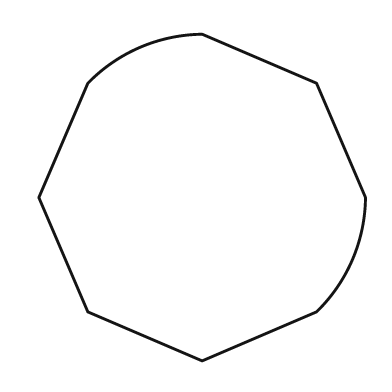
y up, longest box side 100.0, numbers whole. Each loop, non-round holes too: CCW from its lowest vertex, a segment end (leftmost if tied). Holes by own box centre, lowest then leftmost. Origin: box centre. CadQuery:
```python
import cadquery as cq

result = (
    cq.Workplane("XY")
    .moveTo(0.0, -50.0)
    .lineTo(35.0, -35.0)
    .threePointArc((46.0, -19.0), (50.0, 0.0))
    .lineTo(35.0, 35.0)
    .lineTo(0.0, 50.0)
    .threePointArc((-19.0, 46.0), (-35.0, 35.0))
    .lineTo(-50.0, 0.0)
    .lineTo(-35.0, -35.0)
    .close()
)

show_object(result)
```